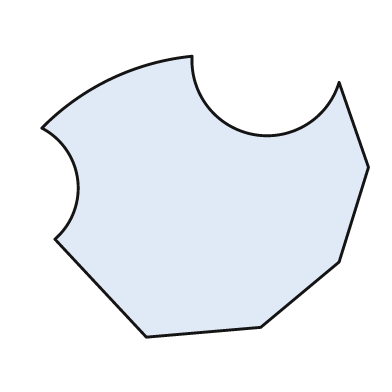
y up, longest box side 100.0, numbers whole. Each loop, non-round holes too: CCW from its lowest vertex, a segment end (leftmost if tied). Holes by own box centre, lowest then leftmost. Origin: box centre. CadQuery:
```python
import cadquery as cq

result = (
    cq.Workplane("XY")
    .moveTo(-18.0, -43.0)
    .lineTo(17.0, -40.0)
    .lineTo(41.0, -20.0)
    .lineTo(50.0, 9.0)
    .lineTo(41.0, 35.0)
    .threePointArc((15.0, 19.0), (-4.0, 43.0))
    .threePointArc((-29.0, 36.0), (-50.0, 21.0))
    .threePointArc((-39.0, 5.0), (-46.0, -13.0))
    .close()
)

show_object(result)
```